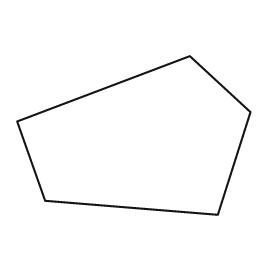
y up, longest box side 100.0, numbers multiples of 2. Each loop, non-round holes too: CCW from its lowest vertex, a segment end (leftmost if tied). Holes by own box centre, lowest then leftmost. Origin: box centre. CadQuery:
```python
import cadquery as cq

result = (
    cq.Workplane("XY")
    .moveTo(36.0, -34.0)
    .lineTo(50.0, 10.0)
    .lineTo(24.0, 34.0)
    .lineTo(-50.0, 6.0)
    .lineTo(-38.0, -28.0)
    .close()
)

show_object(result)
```